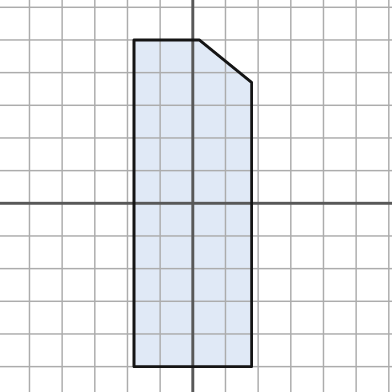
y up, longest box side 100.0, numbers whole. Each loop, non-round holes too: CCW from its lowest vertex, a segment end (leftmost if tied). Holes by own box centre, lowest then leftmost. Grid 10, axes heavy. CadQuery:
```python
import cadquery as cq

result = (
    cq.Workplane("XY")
    .moveTo(-18.0, -50.0)
    .lineTo(18.0, -50.0)
    .lineTo(18.0, 37.0)
    .lineTo(2.0, 50.0)
    .lineTo(-18.0, 50.0)
    .close()
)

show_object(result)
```